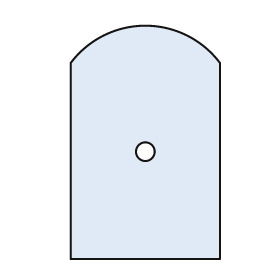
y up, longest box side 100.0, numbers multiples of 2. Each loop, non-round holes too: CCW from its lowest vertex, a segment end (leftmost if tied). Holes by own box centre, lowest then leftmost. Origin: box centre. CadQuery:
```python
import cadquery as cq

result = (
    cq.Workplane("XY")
    .moveTo(-32.0, -50.0)
    .lineTo(32.0, -50.0)
    .lineTo(32.0, 34.0)
    .threePointArc((0.0, 50.0), (-32.0, 34.0))
    .close()
    .moveTo(0.0, -4.0)
    .circle(4.0)
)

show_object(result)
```